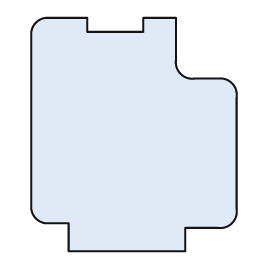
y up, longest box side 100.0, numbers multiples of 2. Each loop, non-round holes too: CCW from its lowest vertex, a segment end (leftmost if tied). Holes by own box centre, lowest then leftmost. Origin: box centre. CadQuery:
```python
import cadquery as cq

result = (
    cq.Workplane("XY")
    .moveTo(-28.0, -50.0)
    .lineTo(22.0, -50.0)
    .lineTo(22.0, -40.0)
    .lineTo(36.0, -40.0)
    .threePointArc((42.0, -38.0), (44.0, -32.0))
    .lineTo(44.0, 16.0)
    .threePointArc((42.0, 22.0), (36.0, 24.0))
    .lineTo(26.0, 24.0)
    .threePointArc((20.0, 26.0), (18.0, 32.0))
    .lineTo(18.0, 50.0)
    .lineTo(4.0, 50.0)
    .lineTo(4.0, 44.0)
    .lineTo(-20.0, 44.0)
    .lineTo(-20.0, 50.0)
    .lineTo(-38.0, 50.0)
    .threePointArc((-42.0, 48.0), (-44.0, 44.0))
    .lineTo(-44.0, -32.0)
    .threePointArc((-42.0, -36.0), (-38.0, -38.0))
    .lineTo(-28.0, -38.0)
    .close()
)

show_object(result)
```